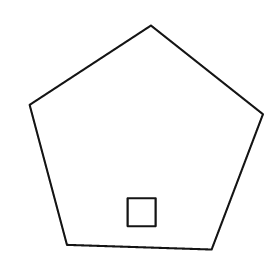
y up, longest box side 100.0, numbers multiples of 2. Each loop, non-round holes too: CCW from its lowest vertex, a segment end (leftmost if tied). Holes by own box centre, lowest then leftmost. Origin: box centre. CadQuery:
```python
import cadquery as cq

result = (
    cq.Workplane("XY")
    .moveTo(28.0, -48.0)
    .lineTo(50.0, 10.0)
    .lineTo(2.0, 48.0)
    .lineTo(-50.0, 14.0)
    .lineTo(-34.0, -46.0)
    .close()
    .moveTo(-8.0, -38.0)
    .lineTo(4.0, -38.0)
    .lineTo(4.0, -26.0)
    .lineTo(-8.0, -26.0)
    .close()
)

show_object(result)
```